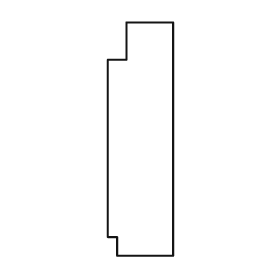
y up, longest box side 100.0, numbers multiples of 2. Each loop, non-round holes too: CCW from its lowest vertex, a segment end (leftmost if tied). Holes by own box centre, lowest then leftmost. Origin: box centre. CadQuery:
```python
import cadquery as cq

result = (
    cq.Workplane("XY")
    .moveTo(-10.0, -50.0)
    .lineTo(14.0, -50.0)
    .lineTo(14.0, 50.0)
    .lineTo(-6.0, 50.0)
    .lineTo(-6.0, 34.0)
    .lineTo(-14.0, 34.0)
    .lineTo(-14.0, -42.0)
    .lineTo(-10.0, -42.0)
    .close()
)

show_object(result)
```